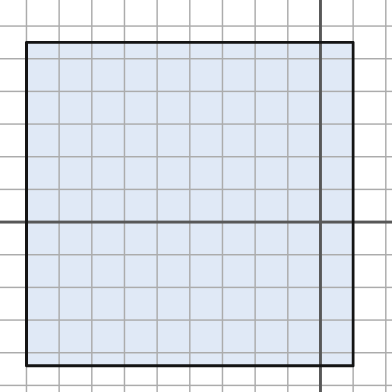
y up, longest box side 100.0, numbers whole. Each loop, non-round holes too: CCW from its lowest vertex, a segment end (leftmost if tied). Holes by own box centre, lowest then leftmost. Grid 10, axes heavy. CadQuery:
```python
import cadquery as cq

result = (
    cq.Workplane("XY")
    .moveTo(-90.0, -44.0)
    .lineTo(10.0, -44.0)
    .lineTo(10.0, 55.0)
    .lineTo(-90.0, 55.0)
    .close()
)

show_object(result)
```